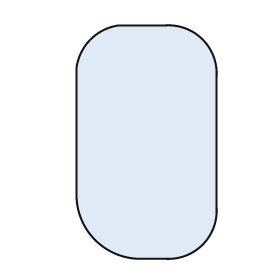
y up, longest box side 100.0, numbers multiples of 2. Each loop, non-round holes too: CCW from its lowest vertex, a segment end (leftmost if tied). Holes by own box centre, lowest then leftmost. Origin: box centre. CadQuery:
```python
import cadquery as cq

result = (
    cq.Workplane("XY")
    .moveTo(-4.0, -50.0)
    .lineTo(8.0, -50.0)
    .threePointArc((24.0, -44.0), (30.0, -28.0))
    .lineTo(30.0, 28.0)
    .threePointArc((24.0, 44.0), (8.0, 50.0))
    .lineTo(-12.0, 50.0)
    .threePointArc((-24.0, 44.0), (-30.0, 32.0))
    .lineTo(-30.0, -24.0)
    .threePointArc((-22.0, -42.0), (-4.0, -50.0))
    .close()
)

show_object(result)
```